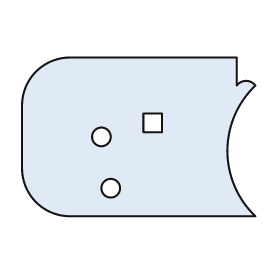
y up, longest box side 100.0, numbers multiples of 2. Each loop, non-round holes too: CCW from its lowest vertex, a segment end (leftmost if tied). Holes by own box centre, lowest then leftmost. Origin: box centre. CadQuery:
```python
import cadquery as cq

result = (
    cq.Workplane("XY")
    .moveTo(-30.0, -34.0)
    .lineTo(50.0, -34.0)
    .threePointArc((38.0, -6.0), (50.0, 22.0))
    .threePointArc((46.0, 24.0), (42.0, 22.0))
    .lineTo(42.0, 34.0)
    .lineTo(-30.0, 34.0)
    .threePointArc((-44.0, 28.0), (-50.0, 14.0))
    .lineTo(-50.0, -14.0)
    .threePointArc((-44.0, -28.0), (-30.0, -34.0))
    .close()
    .moveTo(-12.0, -22.0)
    .circle(4.0)
    .moveTo(-16.0, 0.0)
    .circle(4.0)
    .moveTo(2.0, 2.0)
    .lineTo(10.0, 2.0)
    .lineTo(10.0, 10.0)
    .lineTo(2.0, 10.0)
    .close()
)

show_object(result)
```